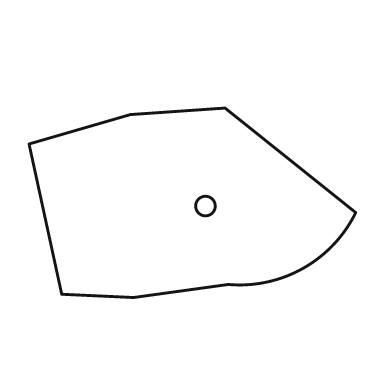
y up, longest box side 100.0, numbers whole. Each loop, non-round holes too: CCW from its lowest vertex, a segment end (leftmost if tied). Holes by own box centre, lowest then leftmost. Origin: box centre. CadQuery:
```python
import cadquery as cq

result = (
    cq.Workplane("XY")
    .moveTo(-18.0, -29.0)
    .lineTo(11.0, -25.0)
    .threePointArc((34.0, -20.0), (50.0, -3.0))
    .lineTo(10.0, 29.0)
    .lineTo(-19.0, 27.0)
    .lineTo(-50.0, 18.0)
    .lineTo(-40.0, -28.0)
    .close()
    .moveTo(4.0, -1.0)
    .circle(3.0)
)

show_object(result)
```